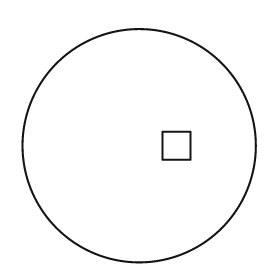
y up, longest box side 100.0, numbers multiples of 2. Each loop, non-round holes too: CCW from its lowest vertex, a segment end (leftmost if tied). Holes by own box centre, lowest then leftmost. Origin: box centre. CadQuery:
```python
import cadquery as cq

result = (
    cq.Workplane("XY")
    .moveTo(0.0, 0.0)
    .circle(50.0)
    .moveTo(10.0, -6.0)
    .lineTo(22.0, -6.0)
    .lineTo(22.0, 6.0)
    .lineTo(10.0, 6.0)
    .close()
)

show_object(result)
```